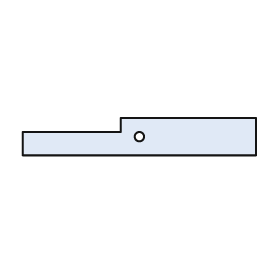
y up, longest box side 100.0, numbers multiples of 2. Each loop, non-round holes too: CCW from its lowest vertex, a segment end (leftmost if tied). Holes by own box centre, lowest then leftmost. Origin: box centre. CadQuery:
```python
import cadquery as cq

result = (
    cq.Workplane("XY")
    .moveTo(-50.0, -8.0)
    .lineTo(50.0, -8.0)
    .lineTo(50.0, 8.0)
    .lineTo(-8.0, 8.0)
    .lineTo(-8.0, 2.0)
    .lineTo(-50.0, 2.0)
    .close()
    .moveTo(0.0, 0.0)
    .circle(2.0)
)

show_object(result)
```